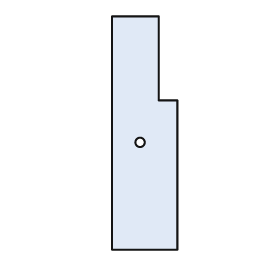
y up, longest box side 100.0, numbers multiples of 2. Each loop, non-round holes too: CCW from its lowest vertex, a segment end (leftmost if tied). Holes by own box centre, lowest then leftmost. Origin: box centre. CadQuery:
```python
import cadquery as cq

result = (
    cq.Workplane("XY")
    .moveTo(-14.0, -50.0)
    .lineTo(14.0, -50.0)
    .lineTo(14.0, 14.0)
    .lineTo(6.0, 14.0)
    .lineTo(6.0, 50.0)
    .lineTo(-14.0, 50.0)
    .close()
    .moveTo(-2.0, -4.0)
    .circle(2.0)
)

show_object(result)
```